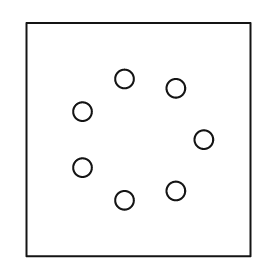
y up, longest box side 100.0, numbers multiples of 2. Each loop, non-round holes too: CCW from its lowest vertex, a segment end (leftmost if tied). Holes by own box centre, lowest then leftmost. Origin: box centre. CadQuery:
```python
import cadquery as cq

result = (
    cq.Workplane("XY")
    .moveTo(-48.0, -50.0)
    .lineTo(48.0, -50.0)
    .lineTo(48.0, 50.0)
    .lineTo(-48.0, 50.0)
    .close()
    .moveTo(-6.0, -26.0)
    .circle(4.0)
    .moveTo(16.0, -22.0)
    .circle(4.0)
    .moveTo(-24.0, -12.0)
    .circle(4.0)
    .moveTo(28.0, 0.0)
    .circle(4.0)
    .moveTo(-24.0, 12.0)
    .circle(4.0)
    .moveTo(16.0, 22.0)
    .circle(4.0)
    .moveTo(-6.0, 26.0)
    .circle(4.0)
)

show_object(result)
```